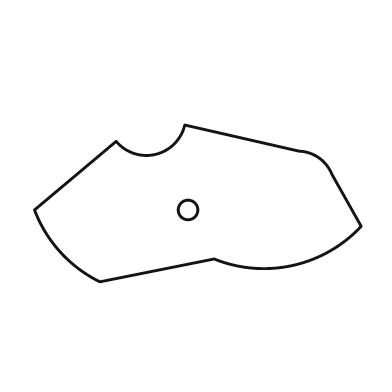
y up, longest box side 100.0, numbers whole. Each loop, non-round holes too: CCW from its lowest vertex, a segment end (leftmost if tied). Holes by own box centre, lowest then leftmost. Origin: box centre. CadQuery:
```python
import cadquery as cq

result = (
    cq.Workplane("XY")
    .moveTo(-30.0, -24.0)
    .lineTo(5.0, -17.0)
    .threePointArc((29.0, -19.0), (50.0, -7.0))
    .lineTo(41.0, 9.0)
    .threePointArc((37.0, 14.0), (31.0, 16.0))
    .lineTo(-4.0, 24.0)
    .threePointArc((-13.0, 15.0), (-25.0, 19.0))
    .lineTo(-50.0, -2.0)
    .threePointArc((-42.0, -15.0), (-30.0, -24.0))
    .close()
    .moveTo(-3.0, -2.0)
    .circle(3.0)
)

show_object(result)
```